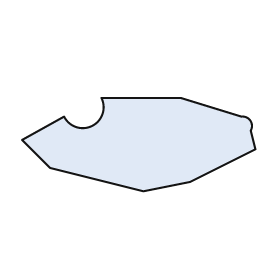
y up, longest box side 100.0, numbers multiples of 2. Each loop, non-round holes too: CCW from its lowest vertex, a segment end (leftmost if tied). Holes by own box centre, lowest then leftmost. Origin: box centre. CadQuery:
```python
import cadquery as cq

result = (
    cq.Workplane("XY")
    .moveTo(2.0, -20.0)
    .lineTo(22.0, -16.0)
    .lineTo(50.0, -2.0)
    .lineTo(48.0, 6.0)
    .threePointArc((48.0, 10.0), (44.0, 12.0))
    .lineTo(18.0, 20.0)
    .lineTo(-16.0, 20.0)
    .threePointArc((-20.0, 8.0), (-32.0, 12.0))
    .lineTo(-50.0, 2.0)
    .lineTo(-38.0, -10.0)
    .close()
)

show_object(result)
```